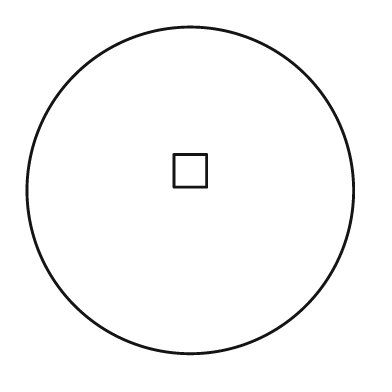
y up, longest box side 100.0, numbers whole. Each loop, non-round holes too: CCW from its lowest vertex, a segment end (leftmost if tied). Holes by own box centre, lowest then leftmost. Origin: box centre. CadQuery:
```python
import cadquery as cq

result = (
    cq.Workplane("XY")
    .moveTo(0.0, 0.0)
    .circle(50.0)
    .moveTo(-5.0, 1.0)
    .lineTo(5.0, 1.0)
    .lineTo(5.0, 11.0)
    .lineTo(-5.0, 11.0)
    .close()
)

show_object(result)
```